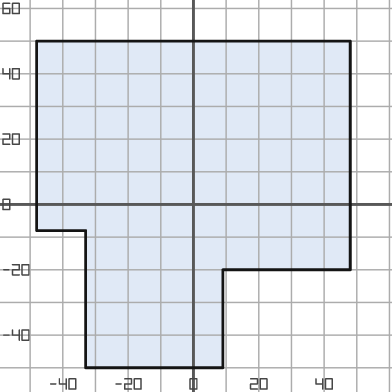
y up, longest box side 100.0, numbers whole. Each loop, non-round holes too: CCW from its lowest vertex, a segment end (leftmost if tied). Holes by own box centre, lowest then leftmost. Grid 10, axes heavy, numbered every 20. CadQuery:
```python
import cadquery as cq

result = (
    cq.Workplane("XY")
    .moveTo(-33.0, -50.0)
    .lineTo(9.0, -50.0)
    .lineTo(9.0, -20.0)
    .lineTo(48.0, -20.0)
    .lineTo(48.0, 50.0)
    .lineTo(-48.0, 50.0)
    .lineTo(-48.0, -8.0)
    .lineTo(-33.0, -8.0)
    .close()
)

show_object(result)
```